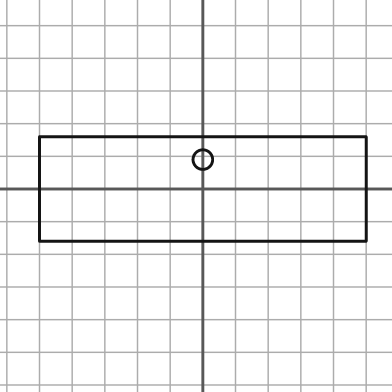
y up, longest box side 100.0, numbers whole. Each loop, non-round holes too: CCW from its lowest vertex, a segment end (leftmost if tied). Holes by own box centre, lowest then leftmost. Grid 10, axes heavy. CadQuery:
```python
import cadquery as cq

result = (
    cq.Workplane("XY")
    .moveTo(-50.0, -16.0)
    .lineTo(50.0, -16.0)
    .lineTo(50.0, 16.0)
    .lineTo(-50.0, 16.0)
    .close()
    .moveTo(0.0, 9.0)
    .circle(3.0)
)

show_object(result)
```